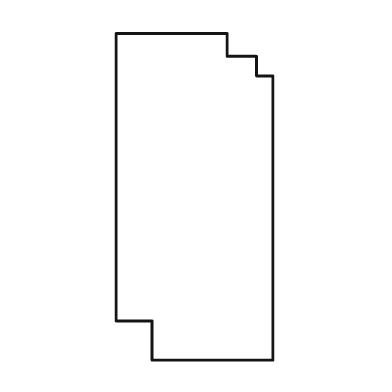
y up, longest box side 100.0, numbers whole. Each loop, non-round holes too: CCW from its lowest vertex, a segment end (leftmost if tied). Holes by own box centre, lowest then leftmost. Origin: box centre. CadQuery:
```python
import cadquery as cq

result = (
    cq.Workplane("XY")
    .moveTo(-13.0, -50.0)
    .lineTo(24.0, -50.0)
    .lineTo(24.0, 37.0)
    .lineTo(19.0, 37.0)
    .lineTo(19.0, 43.0)
    .lineTo(10.0, 43.0)
    .lineTo(10.0, 50.0)
    .lineTo(-24.0, 50.0)
    .lineTo(-24.0, -38.0)
    .lineTo(-13.0, -38.0)
    .close()
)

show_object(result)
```